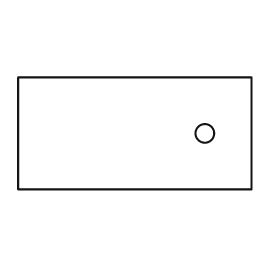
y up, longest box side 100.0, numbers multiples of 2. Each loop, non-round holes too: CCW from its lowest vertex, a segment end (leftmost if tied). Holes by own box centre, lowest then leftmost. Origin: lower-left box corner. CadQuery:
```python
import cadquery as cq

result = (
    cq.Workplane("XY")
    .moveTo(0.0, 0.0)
    .lineTo(100.0, 0.0)
    .lineTo(100.0, 48.0)
    .lineTo(0.0, 48.0)
    .close()
    .moveTo(80.0, 24.0)
    .circle(4.0)
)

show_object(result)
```